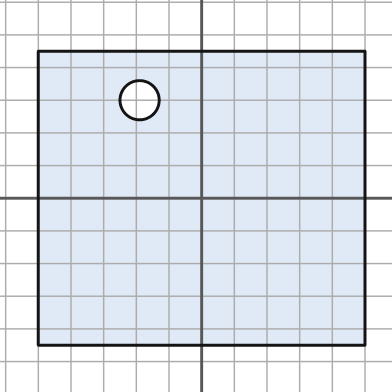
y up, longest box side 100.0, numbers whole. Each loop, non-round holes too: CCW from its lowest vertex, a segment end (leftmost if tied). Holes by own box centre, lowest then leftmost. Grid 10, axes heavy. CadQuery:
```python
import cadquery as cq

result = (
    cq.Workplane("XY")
    .moveTo(-50.0, -45.0)
    .lineTo(50.0, -45.0)
    .lineTo(50.0, 45.0)
    .lineTo(-50.0, 45.0)
    .close()
    .moveTo(-19.0, 30.0)
    .circle(6.0)
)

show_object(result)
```